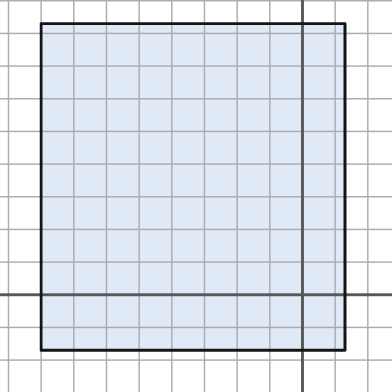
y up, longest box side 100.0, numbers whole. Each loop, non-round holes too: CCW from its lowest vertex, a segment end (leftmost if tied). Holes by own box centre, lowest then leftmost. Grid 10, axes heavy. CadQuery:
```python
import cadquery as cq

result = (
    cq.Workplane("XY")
    .moveTo(-80.0, -17.0)
    .lineTo(13.0, -17.0)
    .lineTo(13.0, 83.0)
    .lineTo(-80.0, 83.0)
    .close()
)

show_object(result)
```